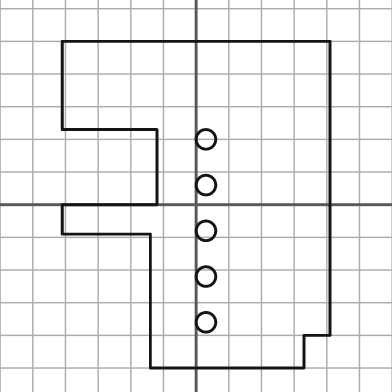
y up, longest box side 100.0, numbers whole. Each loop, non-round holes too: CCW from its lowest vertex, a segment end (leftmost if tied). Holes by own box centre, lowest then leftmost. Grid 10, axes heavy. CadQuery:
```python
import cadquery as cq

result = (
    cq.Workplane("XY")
    .moveTo(-14.0, -50.0)
    .lineTo(33.0, -50.0)
    .lineTo(33.0, -40.0)
    .lineTo(41.0, -40.0)
    .lineTo(41.0, 50.0)
    .lineTo(-41.0, 50.0)
    .lineTo(-41.0, 23.0)
    .lineTo(-12.0, 23.0)
    .lineTo(-12.0, 0.0)
    .lineTo(-41.0, 0.0)
    .lineTo(-41.0, -9.0)
    .lineTo(-14.0, -9.0)
    .close()
    .moveTo(3.0, -36.0)
    .circle(3.0)
    .moveTo(3.0, -22.0)
    .circle(3.0)
    .moveTo(3.0, -8.0)
    .circle(3.0)
    .moveTo(3.0, 6.0)
    .circle(3.0)
    .moveTo(3.0, 20.0)
    .circle(3.0)
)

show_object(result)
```